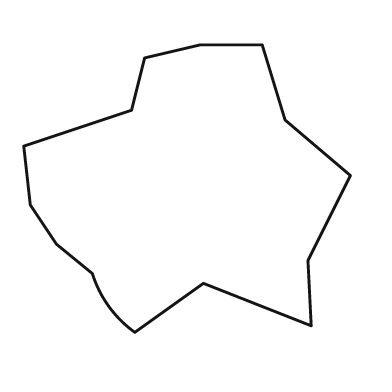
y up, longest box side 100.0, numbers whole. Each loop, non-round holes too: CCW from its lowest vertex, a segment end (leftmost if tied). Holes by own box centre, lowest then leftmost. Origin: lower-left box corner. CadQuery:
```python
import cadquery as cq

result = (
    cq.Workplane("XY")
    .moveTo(34.0, 0.0)
    .lineTo(55.0, 15.0)
    .lineTo(88.0, 2.0)
    .lineTo(87.0, 22.0)
    .lineTo(100.0, 48.0)
    .lineTo(80.0, 65.0)
    .lineTo(73.0, 88.0)
    .lineTo(54.0, 88.0)
    .lineTo(37.0, 84.0)
    .lineTo(33.0, 68.0)
    .lineTo(0.0, 57.0)
    .lineTo(2.0, 39.0)
    .lineTo(10.0, 27.0)
    .lineTo(21.0, 18.0)
    .threePointArc((26.0, 8.0), (34.0, 0.0))
    .close()
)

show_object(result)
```